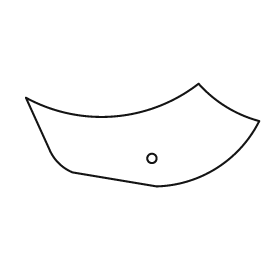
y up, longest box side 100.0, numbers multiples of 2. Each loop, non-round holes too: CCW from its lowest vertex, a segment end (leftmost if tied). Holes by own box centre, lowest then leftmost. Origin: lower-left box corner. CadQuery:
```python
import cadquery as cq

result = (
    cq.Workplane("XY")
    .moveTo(56.0, 0.0)
    .threePointArc((82.0, 8.0), (100.0, 28.0))
    .threePointArc((86.0, 34.0), (74.0, 44.0))
    .threePointArc((38.0, 30.0), (0.0, 38.0))
    .lineTo(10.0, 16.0)
    .threePointArc((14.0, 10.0), (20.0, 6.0))
    .close()
    .moveTo(54.0, 12.0)
    .circle(2.0)
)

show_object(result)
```